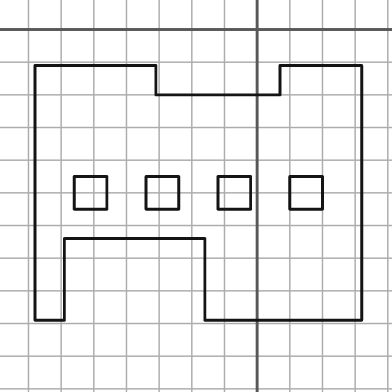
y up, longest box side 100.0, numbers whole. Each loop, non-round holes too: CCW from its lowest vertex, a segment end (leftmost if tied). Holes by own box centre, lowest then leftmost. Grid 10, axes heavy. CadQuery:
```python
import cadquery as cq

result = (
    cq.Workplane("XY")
    .moveTo(-68.0, -89.0)
    .lineTo(-59.0, -89.0)
    .lineTo(-59.0, -64.0)
    .lineTo(-16.0, -64.0)
    .lineTo(-16.0, -89.0)
    .lineTo(32.0, -89.0)
    .lineTo(32.0, -11.0)
    .lineTo(7.0, -11.0)
    .lineTo(7.0, -20.0)
    .lineTo(-31.0, -20.0)
    .lineTo(-31.0, -11.0)
    .lineTo(-68.0, -11.0)
    .close()
    .moveTo(-56.0, -55.0)
    .lineTo(-46.0, -55.0)
    .lineTo(-46.0, -45.0)
    .lineTo(-56.0, -45.0)
    .close()
    .moveTo(-34.0, -55.0)
    .lineTo(-24.0, -55.0)
    .lineTo(-24.0, -45.0)
    .lineTo(-34.0, -45.0)
    .close()
    .moveTo(-12.0, -55.0)
    .lineTo(-2.0, -55.0)
    .lineTo(-2.0, -45.0)
    .lineTo(-12.0, -45.0)
    .close()
    .moveTo(10.0, -55.0)
    .lineTo(20.0, -55.0)
    .lineTo(20.0, -45.0)
    .lineTo(10.0, -45.0)
    .close()
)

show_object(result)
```